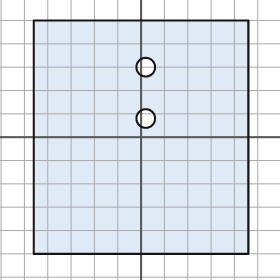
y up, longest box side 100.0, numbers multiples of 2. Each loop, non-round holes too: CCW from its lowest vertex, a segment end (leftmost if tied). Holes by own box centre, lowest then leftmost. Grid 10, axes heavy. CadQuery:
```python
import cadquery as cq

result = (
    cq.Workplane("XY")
    .moveTo(-46.0, -50.0)
    .lineTo(46.0, -50.0)
    .lineTo(46.0, 50.0)
    .lineTo(-46.0, 50.0)
    .close()
    .moveTo(2.0, 8.0)
    .circle(4.0)
    .moveTo(2.0, 30.0)
    .circle(4.0)
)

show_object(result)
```